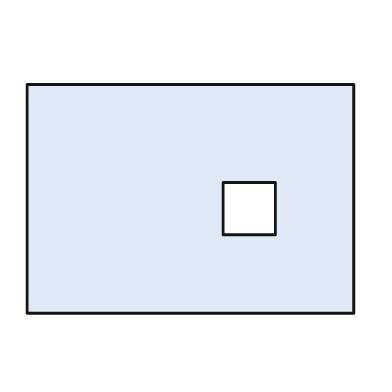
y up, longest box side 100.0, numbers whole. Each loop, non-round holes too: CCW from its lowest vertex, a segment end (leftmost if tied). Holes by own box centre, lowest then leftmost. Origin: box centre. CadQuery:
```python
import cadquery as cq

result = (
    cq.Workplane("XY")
    .moveTo(-50.0, -35.0)
    .lineTo(50.0, -35.0)
    .lineTo(50.0, 35.0)
    .lineTo(-50.0, 35.0)
    .close()
    .moveTo(10.0, -11.0)
    .lineTo(26.0, -11.0)
    .lineTo(26.0, 5.0)
    .lineTo(10.0, 5.0)
    .close()
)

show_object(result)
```